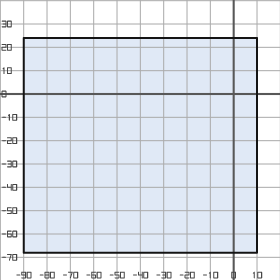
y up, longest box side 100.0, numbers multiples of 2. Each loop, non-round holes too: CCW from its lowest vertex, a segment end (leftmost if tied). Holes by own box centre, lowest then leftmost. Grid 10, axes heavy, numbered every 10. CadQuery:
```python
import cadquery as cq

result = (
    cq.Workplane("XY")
    .moveTo(-90.0, -68.0)
    .lineTo(10.0, -68.0)
    .lineTo(10.0, 24.0)
    .lineTo(-90.0, 24.0)
    .close()
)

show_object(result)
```